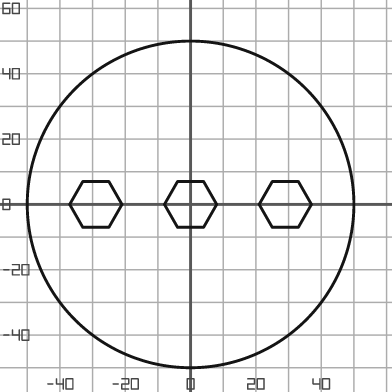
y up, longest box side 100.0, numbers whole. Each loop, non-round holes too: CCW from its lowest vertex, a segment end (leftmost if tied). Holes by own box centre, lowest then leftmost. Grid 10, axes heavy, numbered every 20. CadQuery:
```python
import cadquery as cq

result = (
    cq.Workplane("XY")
    .moveTo(0.0, 0.0)
    .circle(50.0)
    .moveTo(-33.0, -7.0)
    .lineTo(-25.0, -7.0)
    .lineTo(-21.0, 0.0)
    .lineTo(-25.0, 7.0)
    .lineTo(-33.0, 7.0)
    .lineTo(-37.0, 0.0)
    .close()
    .moveTo(-4.0, -7.0)
    .lineTo(4.0, -7.0)
    .lineTo(8.0, 0.0)
    .lineTo(4.0, 7.0)
    .lineTo(-4.0, 7.0)
    .lineTo(-8.0, 0.0)
    .close()
    .moveTo(25.0, -7.0)
    .lineTo(33.0, -7.0)
    .lineTo(37.0, 0.0)
    .lineTo(33.0, 7.0)
    .lineTo(25.0, 7.0)
    .lineTo(21.0, 0.0)
    .close()
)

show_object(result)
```